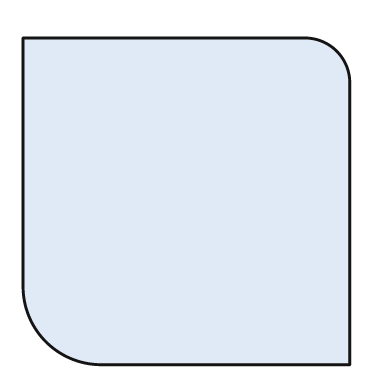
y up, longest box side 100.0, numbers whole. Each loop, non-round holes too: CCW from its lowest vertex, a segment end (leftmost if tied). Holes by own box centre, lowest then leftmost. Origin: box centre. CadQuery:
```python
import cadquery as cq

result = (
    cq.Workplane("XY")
    .moveTo(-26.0, -50.0)
    .lineTo(50.0, -50.0)
    .lineTo(50.0, 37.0)
    .threePointArc((46.0, 46.0), (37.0, 50.0))
    .lineTo(-50.0, 50.0)
    .lineTo(-50.0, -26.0)
    .threePointArc((-43.0, -43.0), (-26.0, -50.0))
    .close()
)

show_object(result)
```